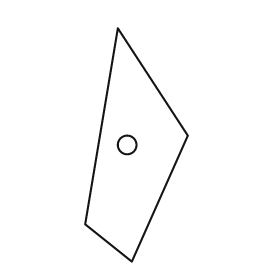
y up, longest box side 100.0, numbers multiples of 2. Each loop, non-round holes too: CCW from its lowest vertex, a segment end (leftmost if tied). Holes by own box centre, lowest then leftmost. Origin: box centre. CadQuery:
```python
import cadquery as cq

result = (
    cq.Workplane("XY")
    .moveTo(-2.0, -50.0)
    .lineTo(22.0, 4.0)
    .lineTo(-8.0, 50.0)
    .lineTo(-22.0, -34.0)
    .close()
    .moveTo(-4.0, 0.0)
    .circle(4.0)
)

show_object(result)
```